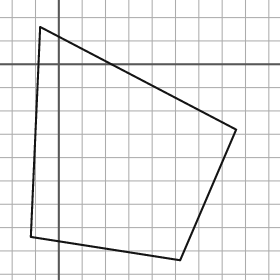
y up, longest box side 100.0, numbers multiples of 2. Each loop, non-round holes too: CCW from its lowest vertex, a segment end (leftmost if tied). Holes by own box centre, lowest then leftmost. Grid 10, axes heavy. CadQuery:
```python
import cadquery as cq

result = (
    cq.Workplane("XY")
    .moveTo(52.0, -84.0)
    .lineTo(76.0, -28.0)
    .lineTo(-8.0, 16.0)
    .lineTo(-12.0, -74.0)
    .close()
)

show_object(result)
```